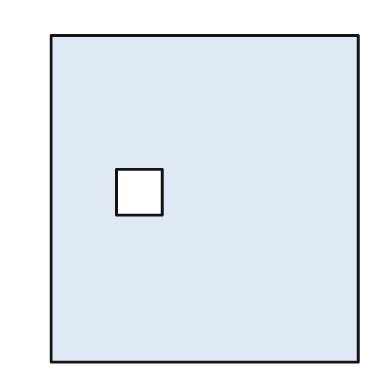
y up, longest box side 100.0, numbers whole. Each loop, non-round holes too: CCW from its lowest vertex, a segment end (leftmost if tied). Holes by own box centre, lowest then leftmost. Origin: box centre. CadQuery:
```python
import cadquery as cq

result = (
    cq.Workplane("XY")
    .moveTo(-47.0, -50.0)
    .lineTo(47.0, -50.0)
    .lineTo(47.0, 50.0)
    .lineTo(-47.0, 50.0)
    .close()
    .moveTo(-27.0, -5.0)
    .lineTo(-13.0, -5.0)
    .lineTo(-13.0, 9.0)
    .lineTo(-27.0, 9.0)
    .close()
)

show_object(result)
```